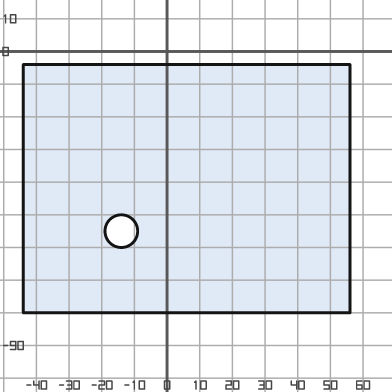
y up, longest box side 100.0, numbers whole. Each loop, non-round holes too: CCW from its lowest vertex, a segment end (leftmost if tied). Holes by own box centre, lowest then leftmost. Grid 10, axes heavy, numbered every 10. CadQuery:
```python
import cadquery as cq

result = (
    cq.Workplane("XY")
    .moveTo(-44.0, -80.0)
    .lineTo(56.0, -80.0)
    .lineTo(56.0, -4.0)
    .lineTo(-44.0, -4.0)
    .close()
    .moveTo(-14.0, -55.0)
    .circle(5.0)
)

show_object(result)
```